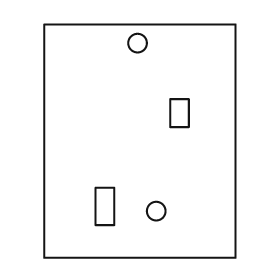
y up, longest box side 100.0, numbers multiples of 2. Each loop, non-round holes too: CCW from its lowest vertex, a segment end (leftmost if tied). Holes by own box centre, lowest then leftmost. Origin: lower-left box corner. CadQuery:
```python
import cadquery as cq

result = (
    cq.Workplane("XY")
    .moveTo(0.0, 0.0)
    .lineTo(82.0, 0.0)
    .lineTo(82.0, 100.0)
    .lineTo(0.0, 100.0)
    .close()
    .moveTo(48.0, 20.0)
    .circle(4.0)
    .moveTo(22.0, 14.0)
    .lineTo(30.0, 14.0)
    .lineTo(30.0, 30.0)
    .lineTo(22.0, 30.0)
    .close()
    .moveTo(54.0, 56.0)
    .lineTo(62.0, 56.0)
    .lineTo(62.0, 68.0)
    .lineTo(54.0, 68.0)
    .close()
    .moveTo(40.0, 92.0)
    .circle(4.0)
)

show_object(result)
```